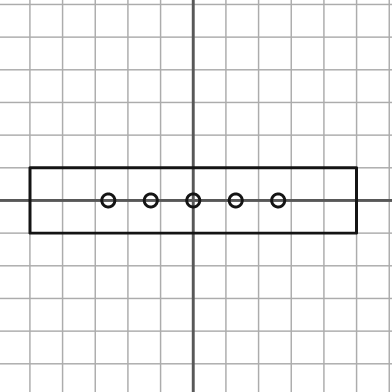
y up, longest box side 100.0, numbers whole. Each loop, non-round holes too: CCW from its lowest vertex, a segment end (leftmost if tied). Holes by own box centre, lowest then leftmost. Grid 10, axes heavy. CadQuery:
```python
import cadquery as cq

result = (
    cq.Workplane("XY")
    .moveTo(-50.0, -10.0)
    .lineTo(50.0, -10.0)
    .lineTo(50.0, 10.0)
    .lineTo(-50.0, 10.0)
    .close()
    .moveTo(-26.0, 0.0)
    .circle(2.0)
    .moveTo(-13.0, 0.0)
    .circle(2.0)
    .moveTo(0.0, 0.0)
    .circle(2.0)
    .moveTo(13.0, 0.0)
    .circle(2.0)
    .moveTo(26.0, 0.0)
    .circle(2.0)
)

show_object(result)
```